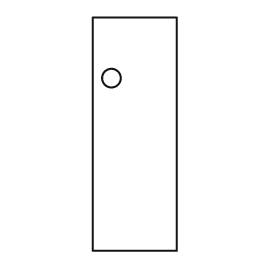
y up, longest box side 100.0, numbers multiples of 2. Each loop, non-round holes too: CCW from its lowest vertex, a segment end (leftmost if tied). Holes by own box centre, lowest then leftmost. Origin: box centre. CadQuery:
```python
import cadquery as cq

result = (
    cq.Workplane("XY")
    .moveTo(-18.0, -50.0)
    .lineTo(18.0, -50.0)
    .lineTo(18.0, 50.0)
    .lineTo(-18.0, 50.0)
    .close()
    .moveTo(-10.0, 24.0)
    .circle(4.0)
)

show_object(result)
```